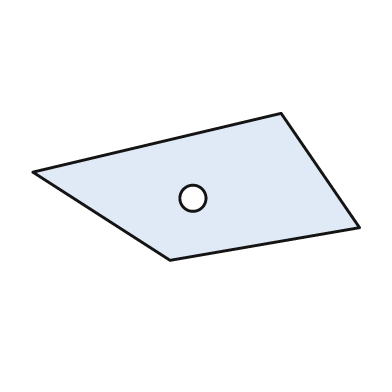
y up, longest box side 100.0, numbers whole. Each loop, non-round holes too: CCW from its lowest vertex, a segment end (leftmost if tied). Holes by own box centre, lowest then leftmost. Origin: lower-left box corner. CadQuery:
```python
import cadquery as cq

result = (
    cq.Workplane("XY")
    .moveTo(42.0, 0.0)
    .lineTo(100.0, 10.0)
    .lineTo(76.0, 45.0)
    .lineTo(0.0, 27.0)
    .close()
    .moveTo(49.0, 19.0)
    .circle(4.0)
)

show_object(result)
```